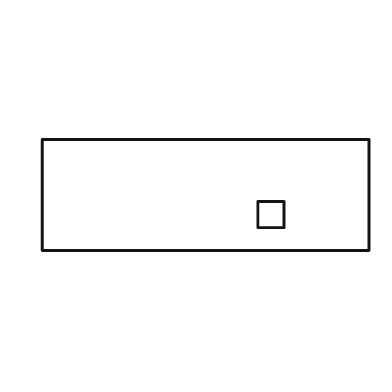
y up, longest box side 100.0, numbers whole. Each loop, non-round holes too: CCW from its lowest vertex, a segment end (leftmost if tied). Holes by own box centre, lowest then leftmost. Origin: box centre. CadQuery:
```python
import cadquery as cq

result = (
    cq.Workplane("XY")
    .moveTo(-50.0, -17.0)
    .lineTo(50.0, -17.0)
    .lineTo(50.0, 17.0)
    .lineTo(-50.0, 17.0)
    .close()
    .moveTo(16.0, -10.0)
    .lineTo(24.0, -10.0)
    .lineTo(24.0, -2.0)
    .lineTo(16.0, -2.0)
    .close()
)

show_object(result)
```